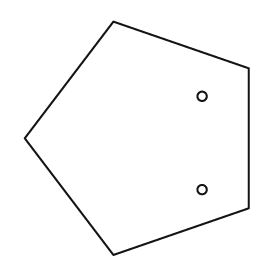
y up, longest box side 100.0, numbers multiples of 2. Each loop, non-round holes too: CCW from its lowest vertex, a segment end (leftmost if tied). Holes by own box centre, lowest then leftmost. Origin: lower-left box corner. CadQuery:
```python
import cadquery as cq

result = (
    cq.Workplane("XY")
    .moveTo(38.0, 0.0)
    .lineTo(96.0, 20.0)
    .lineTo(96.0, 80.0)
    .lineTo(38.0, 100.0)
    .lineTo(0.0, 50.0)
    .close()
    .moveTo(76.0, 28.0)
    .circle(2.0)
    .moveTo(76.0, 68.0)
    .circle(2.0)
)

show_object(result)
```